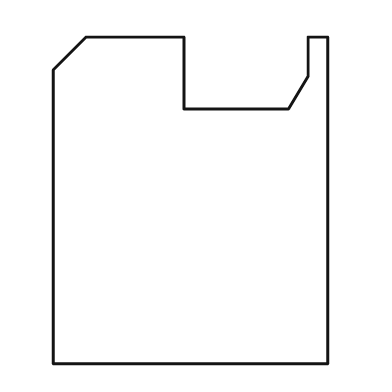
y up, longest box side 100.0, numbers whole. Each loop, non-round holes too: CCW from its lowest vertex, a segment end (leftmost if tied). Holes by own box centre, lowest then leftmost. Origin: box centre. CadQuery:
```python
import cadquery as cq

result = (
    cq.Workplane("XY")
    .moveTo(-42.0, -50.0)
    .lineTo(42.0, -50.0)
    .lineTo(42.0, 50.0)
    .lineTo(36.0, 50.0)
    .lineTo(36.0, 38.0)
    .lineTo(30.0, 28.0)
    .lineTo(-2.0, 28.0)
    .lineTo(-2.0, 50.0)
    .lineTo(-32.0, 50.0)
    .lineTo(-42.0, 40.0)
    .close()
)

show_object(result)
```